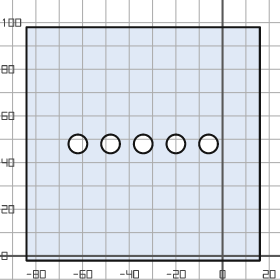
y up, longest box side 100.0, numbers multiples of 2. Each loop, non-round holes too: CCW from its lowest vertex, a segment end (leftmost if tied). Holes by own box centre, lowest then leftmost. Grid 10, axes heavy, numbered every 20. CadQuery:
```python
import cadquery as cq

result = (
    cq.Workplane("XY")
    .moveTo(-84.0, -2.0)
    .lineTo(16.0, -2.0)
    .lineTo(16.0, 98.0)
    .lineTo(-84.0, 98.0)
    .close()
    .moveTo(-62.0, 48.0)
    .circle(4.0)
    .moveTo(-48.0, 48.0)
    .circle(4.0)
    .moveTo(-34.0, 48.0)
    .circle(4.0)
    .moveTo(-20.0, 48.0)
    .circle(4.0)
    .moveTo(-6.0, 48.0)
    .circle(4.0)
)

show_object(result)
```